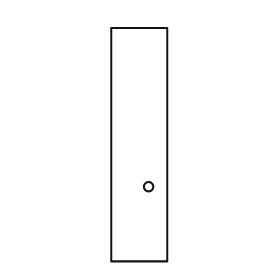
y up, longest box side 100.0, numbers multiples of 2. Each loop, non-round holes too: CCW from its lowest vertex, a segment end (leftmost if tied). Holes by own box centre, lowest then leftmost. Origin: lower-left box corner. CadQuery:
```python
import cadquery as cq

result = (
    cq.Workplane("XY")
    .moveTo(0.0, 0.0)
    .lineTo(24.0, 0.0)
    .lineTo(24.0, 100.0)
    .lineTo(0.0, 100.0)
    .close()
    .moveTo(16.0, 32.0)
    .circle(2.0)
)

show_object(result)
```